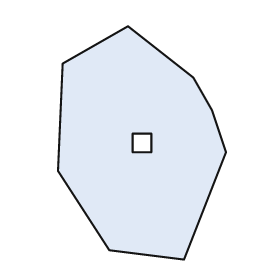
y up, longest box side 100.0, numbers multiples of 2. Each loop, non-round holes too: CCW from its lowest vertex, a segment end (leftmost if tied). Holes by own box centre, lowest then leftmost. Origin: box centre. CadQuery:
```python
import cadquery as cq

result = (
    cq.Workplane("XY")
    .moveTo(18.0, -50.0)
    .lineTo(36.0, -4.0)
    .lineTo(30.0, 14.0)
    .lineTo(22.0, 28.0)
    .lineTo(-6.0, 50.0)
    .lineTo(-34.0, 34.0)
    .lineTo(-36.0, -12.0)
    .lineTo(-14.0, -46.0)
    .close()
    .moveTo(-4.0, -4.0)
    .lineTo(4.0, -4.0)
    .lineTo(4.0, 4.0)
    .lineTo(-4.0, 4.0)
    .close()
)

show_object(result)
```